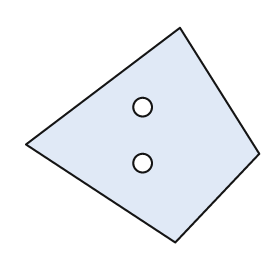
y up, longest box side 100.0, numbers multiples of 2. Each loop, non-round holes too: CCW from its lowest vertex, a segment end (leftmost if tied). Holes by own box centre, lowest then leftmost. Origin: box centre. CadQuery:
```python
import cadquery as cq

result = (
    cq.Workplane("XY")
    .moveTo(14.0, -46.0)
    .lineTo(50.0, -8.0)
    .lineTo(16.0, 46.0)
    .lineTo(-50.0, -4.0)
    .close()
    .moveTo(0.0, -12.0)
    .circle(4.0)
    .moveTo(0.0, 12.0)
    .circle(4.0)
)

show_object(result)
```